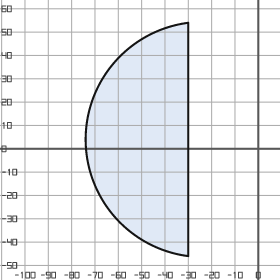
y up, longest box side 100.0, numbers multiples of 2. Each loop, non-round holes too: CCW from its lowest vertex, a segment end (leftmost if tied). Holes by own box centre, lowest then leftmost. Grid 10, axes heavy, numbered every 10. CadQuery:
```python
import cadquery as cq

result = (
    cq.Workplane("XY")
    .moveTo(-30.0, -46.0)
    .lineTo(-30.0, 54.0)
    .threePointArc((-74.0, 4.0), (-30.0, -46.0))
    .close()
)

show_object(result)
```